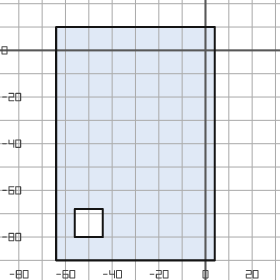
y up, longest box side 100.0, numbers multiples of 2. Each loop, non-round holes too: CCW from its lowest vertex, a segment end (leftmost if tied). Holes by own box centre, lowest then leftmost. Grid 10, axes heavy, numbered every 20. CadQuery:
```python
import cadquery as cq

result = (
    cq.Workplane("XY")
    .moveTo(-64.0, -90.0)
    .lineTo(4.0, -90.0)
    .lineTo(4.0, 10.0)
    .lineTo(-64.0, 10.0)
    .close()
    .moveTo(-56.0, -80.0)
    .lineTo(-44.0, -80.0)
    .lineTo(-44.0, -68.0)
    .lineTo(-56.0, -68.0)
    .close()
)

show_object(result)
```